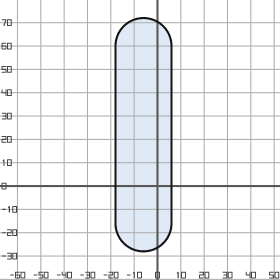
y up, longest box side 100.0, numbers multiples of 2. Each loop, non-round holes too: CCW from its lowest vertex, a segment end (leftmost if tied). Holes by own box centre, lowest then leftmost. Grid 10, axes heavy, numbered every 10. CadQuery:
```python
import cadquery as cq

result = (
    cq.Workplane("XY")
    .moveTo(-18.0, -16.0)
    .threePointArc((-6.0, -28.0), (6.0, -16.0))
    .lineTo(6.0, 60.0)
    .threePointArc((-6.0, 72.0), (-18.0, 60.0))
    .close()
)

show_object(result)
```